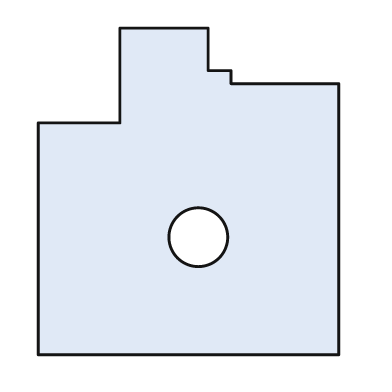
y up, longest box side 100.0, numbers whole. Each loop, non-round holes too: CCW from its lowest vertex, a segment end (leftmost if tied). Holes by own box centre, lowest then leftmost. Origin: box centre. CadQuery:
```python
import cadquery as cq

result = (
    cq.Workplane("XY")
    .moveTo(-46.0, -50.0)
    .lineTo(46.0, -50.0)
    .lineTo(46.0, 33.0)
    .lineTo(13.0, 33.0)
    .lineTo(13.0, 37.0)
    .lineTo(6.0, 37.0)
    .lineTo(6.0, 50.0)
    .lineTo(-21.0, 50.0)
    .lineTo(-21.0, 21.0)
    .lineTo(-46.0, 21.0)
    .close()
    .moveTo(3.0, -14.0)
    .circle(9.0)
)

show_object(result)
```